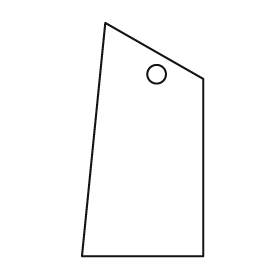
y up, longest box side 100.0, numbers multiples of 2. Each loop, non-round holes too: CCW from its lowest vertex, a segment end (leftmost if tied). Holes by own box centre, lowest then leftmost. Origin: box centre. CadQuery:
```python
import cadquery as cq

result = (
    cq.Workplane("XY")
    .moveTo(-26.0, -50.0)
    .lineTo(26.0, -50.0)
    .lineTo(26.0, 26.0)
    .lineTo(-16.0, 50.0)
    .close()
    .moveTo(6.0, 28.0)
    .circle(4.0)
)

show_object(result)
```